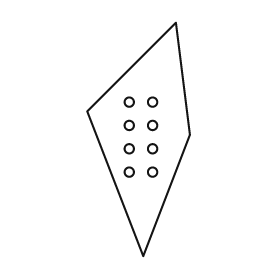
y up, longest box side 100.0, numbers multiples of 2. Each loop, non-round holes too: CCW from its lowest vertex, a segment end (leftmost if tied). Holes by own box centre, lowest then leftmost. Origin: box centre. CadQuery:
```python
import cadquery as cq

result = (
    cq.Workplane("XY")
    .moveTo(2.0, -50.0)
    .lineTo(22.0, 2.0)
    .lineTo(16.0, 50.0)
    .lineTo(-22.0, 12.0)
    .close()
    .moveTo(-4.0, -14.0)
    .circle(2.0)
    .moveTo(6.0, -14.0)
    .circle(2.0)
    .moveTo(-4.0, -4.0)
    .circle(2.0)
    .moveTo(6.0, -4.0)
    .circle(2.0)
    .moveTo(-4.0, 6.0)
    .circle(2.0)
    .moveTo(6.0, 6.0)
    .circle(2.0)
    .moveTo(-4.0, 16.0)
    .circle(2.0)
    .moveTo(6.0, 16.0)
    .circle(2.0)
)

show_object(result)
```